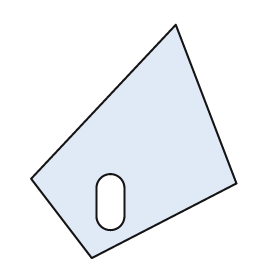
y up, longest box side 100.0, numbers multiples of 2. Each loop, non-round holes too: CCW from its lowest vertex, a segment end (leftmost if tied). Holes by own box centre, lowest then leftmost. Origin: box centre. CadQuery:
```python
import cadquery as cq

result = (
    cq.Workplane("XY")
    .moveTo(-18.0, -50.0)
    .lineTo(44.0, -18.0)
    .lineTo(18.0, 50.0)
    .lineTo(-44.0, -16.0)
    .close()
    .moveTo(-16.0, -32.0)
    .threePointArc((-10.0, -38.0), (-4.0, -32.0))
    .lineTo(-4.0, -20.0)
    .threePointArc((-10.0, -14.0), (-16.0, -20.0))
    .close()
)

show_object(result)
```